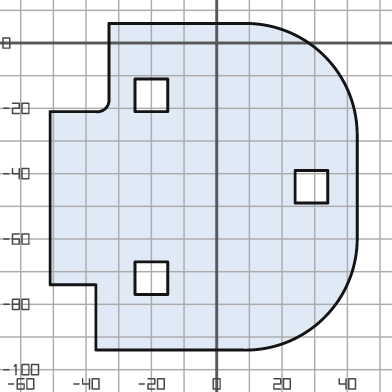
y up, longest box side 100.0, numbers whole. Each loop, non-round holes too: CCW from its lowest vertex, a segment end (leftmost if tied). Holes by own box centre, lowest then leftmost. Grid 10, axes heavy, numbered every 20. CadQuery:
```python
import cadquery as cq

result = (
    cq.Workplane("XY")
    .moveTo(-37.0, -94.0)
    .lineTo(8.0, -94.0)
    .threePointArc((33.0, -84.0), (43.0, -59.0))
    .lineTo(43.0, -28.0)
    .threePointArc((33.0, -4.0), (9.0, 6.0))
    .lineTo(-33.0, 6.0)
    .lineTo(-33.0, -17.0)
    .threePointArc((-34.0, -20.0), (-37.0, -21.0))
    .lineTo(-51.0, -21.0)
    .lineTo(-51.0, -74.0)
    .lineTo(-37.0, -74.0)
    .close()
    .moveTo(-25.0, -77.0)
    .lineTo(-15.0, -77.0)
    .lineTo(-15.0, -67.0)
    .lineTo(-25.0, -67.0)
    .close()
    .moveTo(24.0, -49.0)
    .lineTo(34.0, -49.0)
    .lineTo(34.0, -39.0)
    .lineTo(24.0, -39.0)
    .close()
    .moveTo(-25.0, -21.0)
    .lineTo(-15.0, -21.0)
    .lineTo(-15.0, -11.0)
    .lineTo(-25.0, -11.0)
    .close()
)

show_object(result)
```